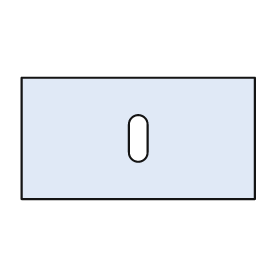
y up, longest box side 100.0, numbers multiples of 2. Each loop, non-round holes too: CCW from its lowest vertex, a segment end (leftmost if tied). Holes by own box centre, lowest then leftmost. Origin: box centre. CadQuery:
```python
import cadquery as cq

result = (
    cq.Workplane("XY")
    .moveTo(-50.0, -26.0)
    .lineTo(50.0, -26.0)
    .lineTo(50.0, 26.0)
    .lineTo(-50.0, 26.0)
    .close()
    .moveTo(-4.0, -6.0)
    .threePointArc((0.0, -10.0), (4.0, -6.0))
    .lineTo(4.0, 6.0)
    .threePointArc((0.0, 10.0), (-4.0, 6.0))
    .close()
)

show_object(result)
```